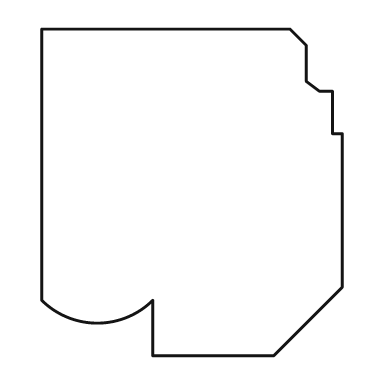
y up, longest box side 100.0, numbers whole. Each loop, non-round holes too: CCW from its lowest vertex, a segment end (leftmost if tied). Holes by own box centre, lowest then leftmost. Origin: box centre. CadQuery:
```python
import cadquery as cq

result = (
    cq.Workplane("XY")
    .moveTo(-12.0, -50.0)
    .lineTo(25.0, -50.0)
    .lineTo(46.0, -29.0)
    .lineTo(46.0, 18.0)
    .lineTo(43.0, 18.0)
    .lineTo(43.0, 31.0)
    .lineTo(39.0, 31.0)
    .lineTo(35.0, 34.0)
    .lineTo(35.0, 45.0)
    .lineTo(30.0, 50.0)
    .lineTo(-46.0, 50.0)
    .lineTo(-46.0, -33.0)
    .threePointArc((-29.0, -40.0), (-12.0, -33.0))
    .close()
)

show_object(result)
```